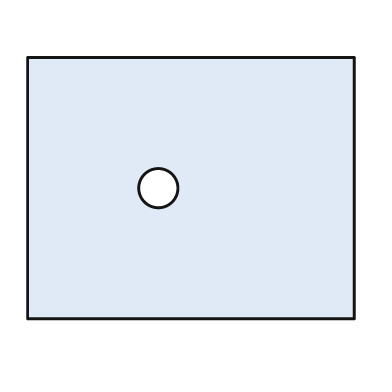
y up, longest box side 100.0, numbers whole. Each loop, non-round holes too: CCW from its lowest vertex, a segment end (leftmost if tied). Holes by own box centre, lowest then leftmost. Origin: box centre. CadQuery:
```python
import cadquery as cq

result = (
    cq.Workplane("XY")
    .moveTo(-50.0, -40.0)
    .lineTo(50.0, -40.0)
    .lineTo(50.0, 40.0)
    .lineTo(-50.0, 40.0)
    .close()
    .moveTo(-10.0, 0.0)
    .circle(6.0)
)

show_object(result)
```